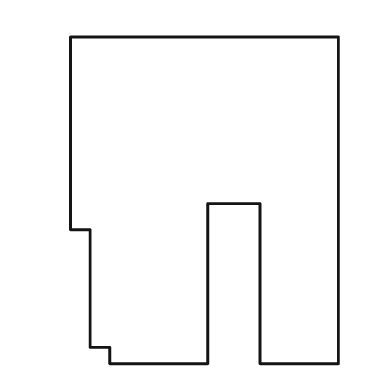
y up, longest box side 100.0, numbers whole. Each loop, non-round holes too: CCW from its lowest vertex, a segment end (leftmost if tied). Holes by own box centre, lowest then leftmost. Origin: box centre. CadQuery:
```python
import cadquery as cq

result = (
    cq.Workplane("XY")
    .moveTo(-29.0, -50.0)
    .lineTo(1.0, -50.0)
    .lineTo(1.0, -1.0)
    .lineTo(17.0, -1.0)
    .lineTo(17.0, -50.0)
    .lineTo(41.0, -50.0)
    .lineTo(41.0, 50.0)
    .lineTo(-41.0, 50.0)
    .lineTo(-41.0, -9.0)
    .lineTo(-35.0, -9.0)
    .lineTo(-35.0, -45.0)
    .lineTo(-29.0, -45.0)
    .close()
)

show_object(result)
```